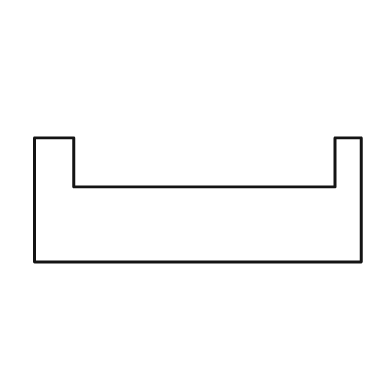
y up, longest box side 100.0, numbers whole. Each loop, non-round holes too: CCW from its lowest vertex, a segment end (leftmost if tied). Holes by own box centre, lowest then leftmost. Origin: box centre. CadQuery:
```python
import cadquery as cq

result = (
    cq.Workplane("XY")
    .moveTo(-50.0, -19.0)
    .lineTo(50.0, -19.0)
    .lineTo(50.0, 19.0)
    .lineTo(42.0, 19.0)
    .lineTo(42.0, 4.0)
    .lineTo(-38.0, 4.0)
    .lineTo(-38.0, 19.0)
    .lineTo(-50.0, 19.0)
    .close()
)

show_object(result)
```